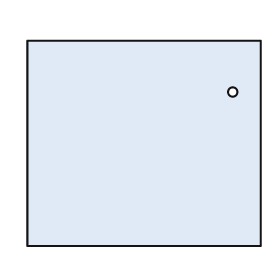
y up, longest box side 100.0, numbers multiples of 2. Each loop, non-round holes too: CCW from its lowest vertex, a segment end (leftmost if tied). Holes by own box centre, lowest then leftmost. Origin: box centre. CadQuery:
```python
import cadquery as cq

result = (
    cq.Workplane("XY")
    .moveTo(-50.0, -44.0)
    .lineTo(50.0, -44.0)
    .lineTo(50.0, 44.0)
    .lineTo(-50.0, 44.0)
    .close()
    .moveTo(38.0, 22.0)
    .circle(2.0)
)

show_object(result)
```